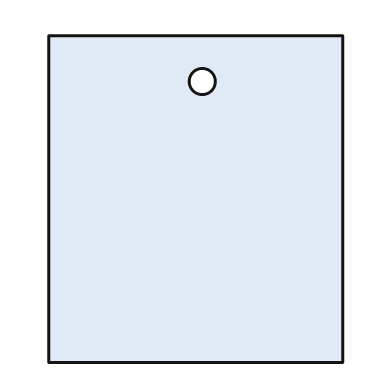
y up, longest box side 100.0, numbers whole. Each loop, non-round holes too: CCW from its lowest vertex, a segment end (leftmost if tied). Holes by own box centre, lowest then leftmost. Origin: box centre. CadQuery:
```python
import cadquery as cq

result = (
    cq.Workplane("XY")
    .moveTo(-45.0, -50.0)
    .lineTo(45.0, -50.0)
    .lineTo(45.0, 50.0)
    .lineTo(-45.0, 50.0)
    .close()
    .moveTo(2.0, 36.0)
    .circle(4.0)
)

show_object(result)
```